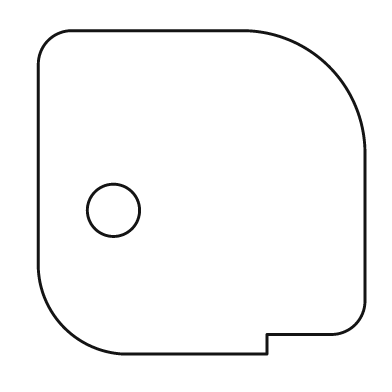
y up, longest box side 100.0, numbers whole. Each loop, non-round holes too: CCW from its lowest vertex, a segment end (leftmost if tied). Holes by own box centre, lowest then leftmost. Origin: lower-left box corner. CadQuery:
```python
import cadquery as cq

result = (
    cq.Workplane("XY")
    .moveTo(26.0, 0.0)
    .lineTo(70.0, 0.0)
    .lineTo(70.0, 6.0)
    .lineTo(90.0, 6.0)
    .threePointArc((97.0, 9.0), (100.0, 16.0))
    .lineTo(100.0, 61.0)
    .threePointArc((89.0, 88.0), (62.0, 99.0))
    .lineTo(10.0, 99.0)
    .threePointArc((3.0, 96.0), (0.0, 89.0))
    .lineTo(0.0, 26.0)
    .threePointArc((8.0, 8.0), (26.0, 0.0))
    .close()
    .moveTo(23.0, 44.0)
    .circle(8.0)
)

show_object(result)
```